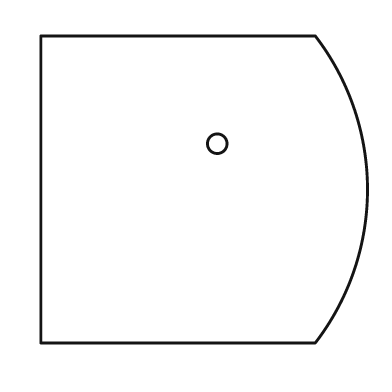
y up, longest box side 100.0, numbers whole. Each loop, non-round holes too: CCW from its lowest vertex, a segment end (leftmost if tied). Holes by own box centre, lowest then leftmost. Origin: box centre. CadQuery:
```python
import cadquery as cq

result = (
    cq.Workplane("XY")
    .moveTo(-50.0, -47.0)
    .lineTo(34.0, -47.0)
    .threePointArc((50.0, 0.0), (34.0, 47.0))
    .lineTo(-50.0, 47.0)
    .close()
    .moveTo(4.0, 14.0)
    .circle(3.0)
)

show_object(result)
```